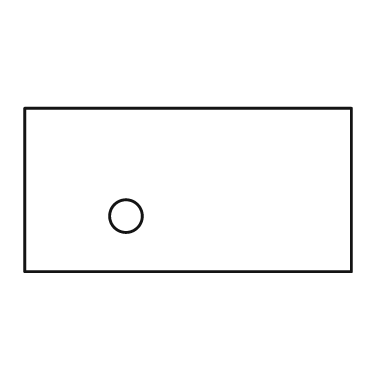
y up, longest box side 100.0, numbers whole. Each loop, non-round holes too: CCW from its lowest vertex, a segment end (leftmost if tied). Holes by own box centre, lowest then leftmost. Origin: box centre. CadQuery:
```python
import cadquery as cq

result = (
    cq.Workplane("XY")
    .moveTo(-50.0, -25.0)
    .lineTo(50.0, -25.0)
    .lineTo(50.0, 25.0)
    .lineTo(-50.0, 25.0)
    .close()
    .moveTo(-19.0, -8.0)
    .circle(5.0)
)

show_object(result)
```